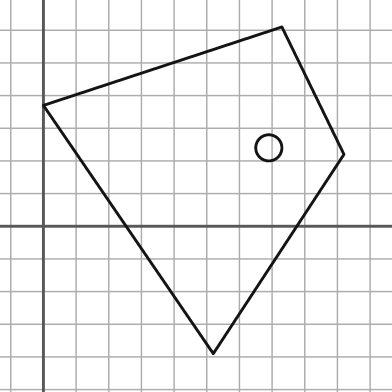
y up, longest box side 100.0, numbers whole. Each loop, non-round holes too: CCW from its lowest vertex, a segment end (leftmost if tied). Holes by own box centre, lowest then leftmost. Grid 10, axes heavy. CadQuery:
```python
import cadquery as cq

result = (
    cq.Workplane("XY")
    .moveTo(52.0, -39.0)
    .lineTo(92.0, 22.0)
    .lineTo(73.0, 61.0)
    .lineTo(0.0, 37.0)
    .close()
    .moveTo(69.0, 24.0)
    .circle(4.0)
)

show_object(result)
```